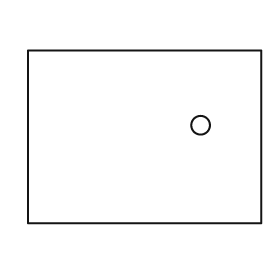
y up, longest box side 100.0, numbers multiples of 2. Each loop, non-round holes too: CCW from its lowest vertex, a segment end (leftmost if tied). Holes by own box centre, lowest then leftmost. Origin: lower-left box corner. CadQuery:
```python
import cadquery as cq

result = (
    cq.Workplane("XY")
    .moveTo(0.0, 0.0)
    .lineTo(100.0, 0.0)
    .lineTo(100.0, 74.0)
    .lineTo(0.0, 74.0)
    .close()
    .moveTo(74.0, 42.0)
    .circle(4.0)
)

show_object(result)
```